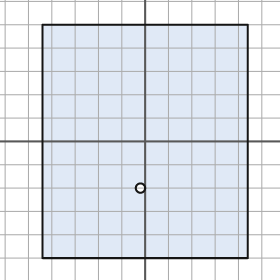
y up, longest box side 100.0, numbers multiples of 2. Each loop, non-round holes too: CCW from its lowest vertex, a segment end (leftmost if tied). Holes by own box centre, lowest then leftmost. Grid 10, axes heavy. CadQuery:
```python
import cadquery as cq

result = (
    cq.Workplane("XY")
    .moveTo(-44.0, -50.0)
    .lineTo(44.0, -50.0)
    .lineTo(44.0, 50.0)
    .lineTo(-44.0, 50.0)
    .close()
    .moveTo(-2.0, -20.0)
    .circle(2.0)
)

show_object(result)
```